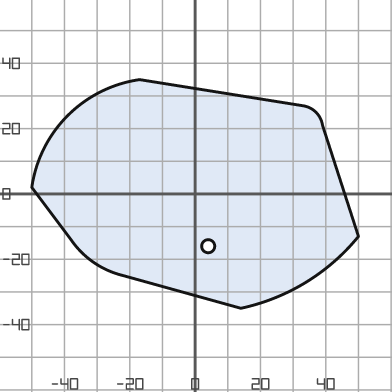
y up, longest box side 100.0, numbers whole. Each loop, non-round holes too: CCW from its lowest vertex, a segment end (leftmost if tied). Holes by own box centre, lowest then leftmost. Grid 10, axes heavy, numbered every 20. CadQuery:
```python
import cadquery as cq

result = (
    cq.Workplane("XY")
    .moveTo(14.0, -35.0)
    .threePointArc((34.0, -27.0), (50.0, -13.0))
    .lineTo(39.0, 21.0)
    .threePointArc((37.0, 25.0), (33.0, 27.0))
    .lineTo(-17.0, 35.0)
    .threePointArc((-39.0, 24.0), (-50.0, 2.0))
    .lineTo(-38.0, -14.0)
    .threePointArc((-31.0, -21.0), (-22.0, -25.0))
    .close()
    .moveTo(4.0, -16.0)
    .circle(2.0)
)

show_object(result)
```